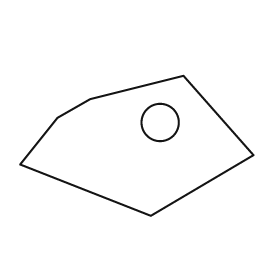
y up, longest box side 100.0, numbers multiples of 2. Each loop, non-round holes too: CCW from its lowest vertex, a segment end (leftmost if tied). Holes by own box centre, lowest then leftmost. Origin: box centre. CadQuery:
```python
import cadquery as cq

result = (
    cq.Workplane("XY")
    .moveTo(6.0, -30.0)
    .lineTo(50.0, -4.0)
    .lineTo(20.0, 30.0)
    .lineTo(-20.0, 20.0)
    .lineTo(-34.0, 12.0)
    .lineTo(-50.0, -8.0)
    .close()
    .moveTo(10.0, 10.0)
    .circle(8.0)
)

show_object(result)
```